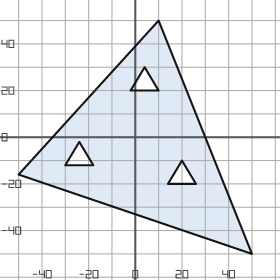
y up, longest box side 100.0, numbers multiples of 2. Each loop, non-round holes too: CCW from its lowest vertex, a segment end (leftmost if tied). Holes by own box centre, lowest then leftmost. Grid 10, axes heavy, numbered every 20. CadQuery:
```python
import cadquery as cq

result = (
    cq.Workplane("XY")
    .moveTo(50.0, -50.0)
    .lineTo(10.0, 50.0)
    .lineTo(-50.0, -16.0)
    .close()
    .moveTo(14.0, -20.0)
    .lineTo(26.0, -20.0)
    .lineTo(20.0, -10.0)
    .close()
    .moveTo(-30.0, -12.0)
    .lineTo(-18.0, -12.0)
    .lineTo(-24.0, -2.0)
    .close()
    .moveTo(-2.0, 20.0)
    .lineTo(10.0, 20.0)
    .lineTo(4.0, 30.0)
    .close()
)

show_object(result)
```